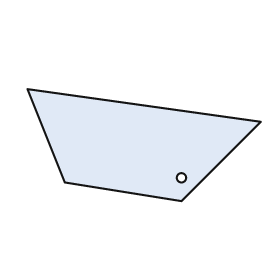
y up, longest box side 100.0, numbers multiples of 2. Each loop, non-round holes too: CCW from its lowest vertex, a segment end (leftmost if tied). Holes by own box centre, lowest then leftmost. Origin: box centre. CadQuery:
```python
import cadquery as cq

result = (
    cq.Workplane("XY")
    .moveTo(16.0, -24.0)
    .lineTo(50.0, 10.0)
    .lineTo(-50.0, 24.0)
    .lineTo(-34.0, -16.0)
    .close()
    .moveTo(16.0, -14.0)
    .circle(2.0)
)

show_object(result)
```